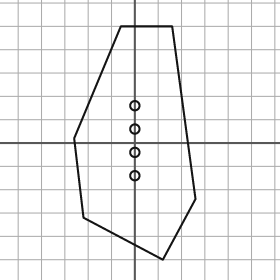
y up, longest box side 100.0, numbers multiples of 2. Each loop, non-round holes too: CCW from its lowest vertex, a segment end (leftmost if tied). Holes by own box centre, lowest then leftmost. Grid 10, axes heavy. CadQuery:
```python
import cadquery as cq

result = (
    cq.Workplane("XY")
    .moveTo(12.0, -50.0)
    .lineTo(26.0, -24.0)
    .lineTo(16.0, 50.0)
    .lineTo(-6.0, 50.0)
    .lineTo(-26.0, 2.0)
    .lineTo(-22.0, -32.0)
    .close()
    .moveTo(0.0, -14.0)
    .circle(2.0)
    .moveTo(0.0, -4.0)
    .circle(2.0)
    .moveTo(0.0, 6.0)
    .circle(2.0)
    .moveTo(0.0, 16.0)
    .circle(2.0)
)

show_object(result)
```